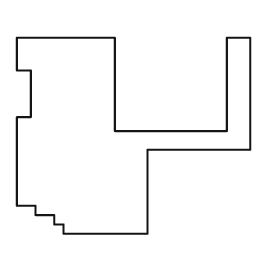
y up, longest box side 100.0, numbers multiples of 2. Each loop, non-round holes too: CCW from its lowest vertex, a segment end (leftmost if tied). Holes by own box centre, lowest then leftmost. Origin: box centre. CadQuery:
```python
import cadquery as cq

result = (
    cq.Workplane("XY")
    .moveTo(-30.0, -42.0)
    .lineTo(6.0, -42.0)
    .lineTo(6.0, -6.0)
    .lineTo(50.0, -6.0)
    .lineTo(50.0, 42.0)
    .lineTo(40.0, 42.0)
    .lineTo(40.0, 2.0)
    .lineTo(-8.0, 2.0)
    .lineTo(-8.0, 42.0)
    .lineTo(-50.0, 42.0)
    .lineTo(-50.0, 28.0)
    .lineTo(-44.0, 28.0)
    .lineTo(-44.0, 8.0)
    .lineTo(-50.0, 8.0)
    .lineTo(-50.0, -30.0)
    .lineTo(-42.0, -30.0)
    .lineTo(-42.0, -34.0)
    .lineTo(-34.0, -34.0)
    .lineTo(-34.0, -38.0)
    .lineTo(-30.0, -38.0)
    .close()
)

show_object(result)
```